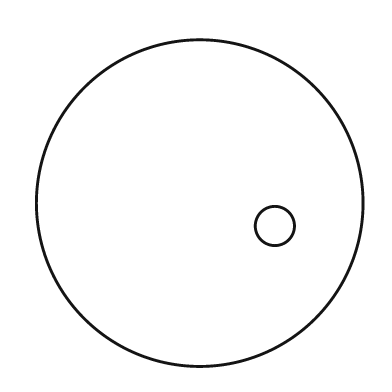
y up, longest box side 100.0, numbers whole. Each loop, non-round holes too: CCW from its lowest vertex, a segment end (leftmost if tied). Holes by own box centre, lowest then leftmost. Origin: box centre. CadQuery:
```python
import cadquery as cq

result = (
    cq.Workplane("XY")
    .moveTo(0.0, 0.0)
    .circle(50.0)
    .moveTo(23.0, -7.0)
    .circle(6.0)
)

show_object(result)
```